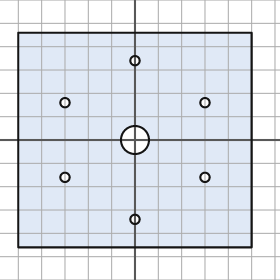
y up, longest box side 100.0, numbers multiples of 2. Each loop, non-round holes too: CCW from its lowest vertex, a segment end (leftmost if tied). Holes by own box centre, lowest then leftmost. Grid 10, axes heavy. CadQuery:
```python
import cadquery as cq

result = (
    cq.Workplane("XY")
    .moveTo(-50.0, -46.0)
    .lineTo(50.0, -46.0)
    .lineTo(50.0, 46.0)
    .lineTo(-50.0, 46.0)
    .close()
    .moveTo(0.0, -34.0)
    .circle(2.0)
    .moveTo(-30.0, -16.0)
    .circle(2.0)
    .moveTo(30.0, -16.0)
    .circle(2.0)
    .moveTo(0.0, 0.0)
    .circle(6.0)
    .moveTo(-30.0, 16.0)
    .circle(2.0)
    .moveTo(30.0, 16.0)
    .circle(2.0)
    .moveTo(0.0, 34.0)
    .circle(2.0)
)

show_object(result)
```